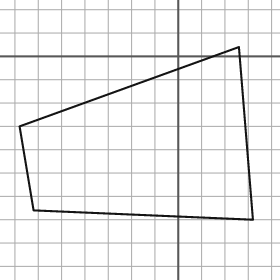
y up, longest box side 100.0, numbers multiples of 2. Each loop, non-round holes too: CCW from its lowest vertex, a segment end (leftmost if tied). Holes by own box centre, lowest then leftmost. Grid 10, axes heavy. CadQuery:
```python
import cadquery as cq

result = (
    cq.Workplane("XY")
    .moveTo(32.0, -70.0)
    .lineTo(26.0, 4.0)
    .lineTo(-68.0, -30.0)
    .lineTo(-62.0, -66.0)
    .close()
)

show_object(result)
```